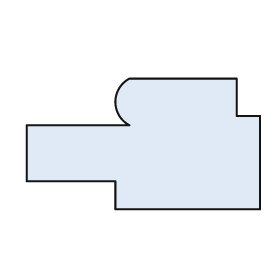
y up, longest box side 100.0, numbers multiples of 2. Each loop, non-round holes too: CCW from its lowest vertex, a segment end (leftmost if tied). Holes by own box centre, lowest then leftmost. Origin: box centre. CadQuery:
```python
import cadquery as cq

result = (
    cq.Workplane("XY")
    .moveTo(-12.0, -28.0)
    .lineTo(50.0, -28.0)
    .lineTo(50.0, 12.0)
    .lineTo(40.0, 12.0)
    .lineTo(40.0, 28.0)
    .lineTo(-6.0, 28.0)
    .threePointArc((-12.0, 18.0), (-6.0, 8.0))
    .lineTo(-50.0, 8.0)
    .lineTo(-50.0, -16.0)
    .lineTo(-12.0, -16.0)
    .close()
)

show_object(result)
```